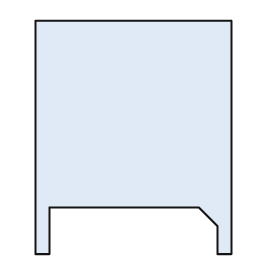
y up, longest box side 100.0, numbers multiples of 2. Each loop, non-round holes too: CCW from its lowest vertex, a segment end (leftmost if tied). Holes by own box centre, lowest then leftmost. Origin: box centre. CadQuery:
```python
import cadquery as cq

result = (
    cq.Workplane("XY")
    .moveTo(-42.0, -50.0)
    .lineTo(-36.0, -50.0)
    .lineTo(-36.0, -30.0)
    .lineTo(28.0, -30.0)
    .lineTo(36.0, -38.0)
    .lineTo(36.0, -50.0)
    .lineTo(42.0, -50.0)
    .lineTo(42.0, 50.0)
    .lineTo(-42.0, 50.0)
    .close()
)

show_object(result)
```